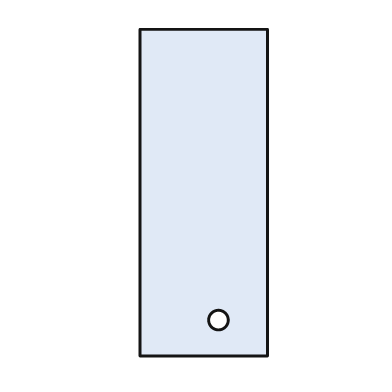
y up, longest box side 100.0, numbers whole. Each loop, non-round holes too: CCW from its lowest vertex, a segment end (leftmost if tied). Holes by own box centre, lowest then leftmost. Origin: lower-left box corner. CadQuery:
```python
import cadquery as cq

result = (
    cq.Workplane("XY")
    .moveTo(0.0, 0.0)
    .lineTo(39.0, 0.0)
    .lineTo(39.0, 100.0)
    .lineTo(0.0, 100.0)
    .close()
    .moveTo(24.0, 11.0)
    .circle(3.0)
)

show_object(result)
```